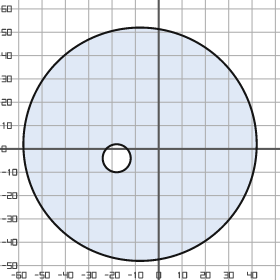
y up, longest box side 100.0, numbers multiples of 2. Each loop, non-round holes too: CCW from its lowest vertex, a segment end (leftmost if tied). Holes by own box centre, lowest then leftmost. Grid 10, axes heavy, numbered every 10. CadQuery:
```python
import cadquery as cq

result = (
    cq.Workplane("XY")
    .moveTo(-8.0, 2.0)
    .circle(50.0)
    .moveTo(-18.0, -4.0)
    .circle(6.0)
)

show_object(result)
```